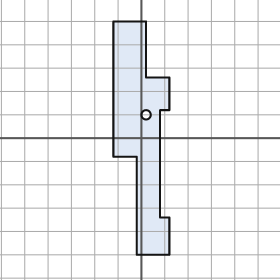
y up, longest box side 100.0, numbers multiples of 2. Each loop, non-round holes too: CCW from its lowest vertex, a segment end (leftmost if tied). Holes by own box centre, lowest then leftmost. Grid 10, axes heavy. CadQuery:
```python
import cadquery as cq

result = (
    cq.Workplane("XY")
    .moveTo(-2.0, -50.0)
    .lineTo(12.0, -50.0)
    .lineTo(12.0, -34.0)
    .lineTo(8.0, -34.0)
    .lineTo(8.0, 12.0)
    .lineTo(12.0, 12.0)
    .lineTo(12.0, 26.0)
    .lineTo(2.0, 26.0)
    .lineTo(2.0, 50.0)
    .lineTo(-12.0, 50.0)
    .lineTo(-12.0, -8.0)
    .lineTo(-2.0, -8.0)
    .close()
    .moveTo(2.0, 10.0)
    .circle(2.0)
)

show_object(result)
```